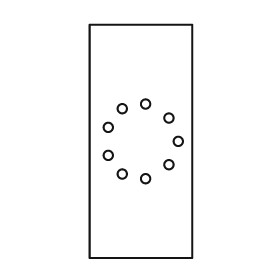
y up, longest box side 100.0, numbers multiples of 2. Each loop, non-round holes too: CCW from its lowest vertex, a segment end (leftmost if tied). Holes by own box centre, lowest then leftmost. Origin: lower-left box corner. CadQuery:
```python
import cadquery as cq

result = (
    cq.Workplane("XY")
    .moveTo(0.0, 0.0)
    .lineTo(44.0, 0.0)
    .lineTo(44.0, 100.0)
    .lineTo(0.0, 100.0)
    .close()
    .moveTo(24.0, 34.0)
    .circle(2.0)
    .moveTo(14.0, 36.0)
    .circle(2.0)
    .moveTo(34.0, 40.0)
    .circle(2.0)
    .moveTo(8.0, 44.0)
    .circle(2.0)
    .moveTo(38.0, 50.0)
    .circle(2.0)
    .moveTo(8.0, 56.0)
    .circle(2.0)
    .moveTo(34.0, 60.0)
    .circle(2.0)
    .moveTo(14.0, 64.0)
    .circle(2.0)
    .moveTo(24.0, 66.0)
    .circle(2.0)
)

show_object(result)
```